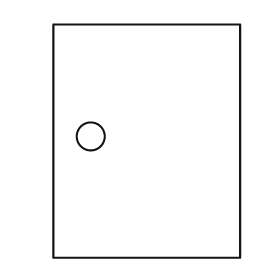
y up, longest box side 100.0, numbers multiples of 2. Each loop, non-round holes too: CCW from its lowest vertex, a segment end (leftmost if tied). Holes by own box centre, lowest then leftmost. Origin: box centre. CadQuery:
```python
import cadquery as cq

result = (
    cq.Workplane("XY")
    .moveTo(-40.0, -50.0)
    .lineTo(40.0, -50.0)
    .lineTo(40.0, 50.0)
    .lineTo(-40.0, 50.0)
    .close()
    .moveTo(-24.0, 2.0)
    .circle(6.0)
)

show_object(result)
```